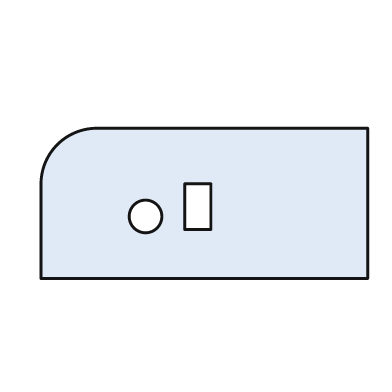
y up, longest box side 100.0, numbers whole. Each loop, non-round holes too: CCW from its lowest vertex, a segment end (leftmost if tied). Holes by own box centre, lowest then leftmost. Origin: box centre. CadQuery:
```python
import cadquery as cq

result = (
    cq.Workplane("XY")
    .moveTo(-50.0, -23.0)
    .lineTo(50.0, -23.0)
    .lineTo(50.0, 23.0)
    .lineTo(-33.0, 23.0)
    .threePointArc((-45.0, 18.0), (-50.0, 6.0))
    .close()
    .moveTo(-18.0, -4.0)
    .circle(5.0)
    .moveTo(-6.0, -8.0)
    .lineTo(2.0, -8.0)
    .lineTo(2.0, 6.0)
    .lineTo(-6.0, 6.0)
    .close()
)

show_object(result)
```